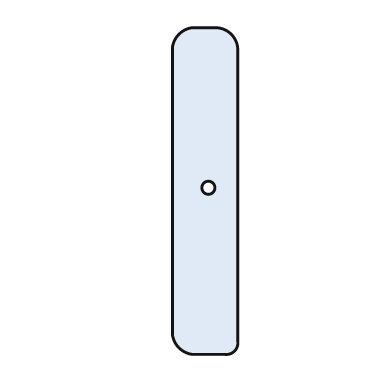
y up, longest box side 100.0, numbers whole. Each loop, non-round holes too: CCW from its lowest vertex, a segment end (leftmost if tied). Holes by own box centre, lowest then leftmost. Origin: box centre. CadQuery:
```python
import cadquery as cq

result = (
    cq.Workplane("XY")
    .moveTo(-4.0, -50.0)
    .lineTo(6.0, -50.0)
    .threePointArc((9.0, -49.0), (10.0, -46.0))
    .lineTo(10.0, 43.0)
    .threePointArc((8.0, 48.0), (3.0, 50.0))
    .lineTo(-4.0, 50.0)
    .threePointArc((-8.0, 48.0), (-10.0, 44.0))
    .lineTo(-10.0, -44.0)
    .threePointArc((-8.0, -48.0), (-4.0, -50.0))
    .close()
    .moveTo(1.0, 1.0)
    .circle(2.0)
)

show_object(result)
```